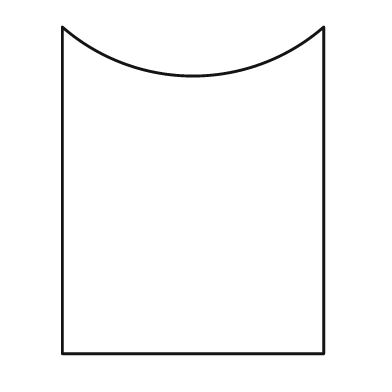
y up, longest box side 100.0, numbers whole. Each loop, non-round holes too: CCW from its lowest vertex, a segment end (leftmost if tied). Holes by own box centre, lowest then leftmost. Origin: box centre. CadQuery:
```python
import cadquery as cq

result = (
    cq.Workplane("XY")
    .moveTo(-40.0, -50.0)
    .lineTo(40.0, -50.0)
    .lineTo(40.0, 50.0)
    .threePointArc((0.0, 35.0), (-40.0, 50.0))
    .close()
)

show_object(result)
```